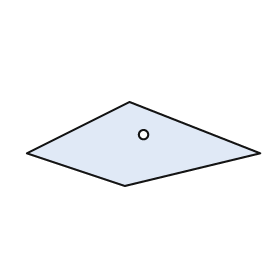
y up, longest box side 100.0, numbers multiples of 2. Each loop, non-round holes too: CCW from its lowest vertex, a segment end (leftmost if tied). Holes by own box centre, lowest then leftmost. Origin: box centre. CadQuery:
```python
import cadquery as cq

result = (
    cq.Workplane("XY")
    .moveTo(-8.0, -18.0)
    .lineTo(50.0, -4.0)
    .lineTo(-6.0, 18.0)
    .lineTo(-50.0, -4.0)
    .close()
    .moveTo(0.0, 4.0)
    .circle(2.0)
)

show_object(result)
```